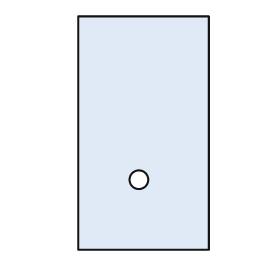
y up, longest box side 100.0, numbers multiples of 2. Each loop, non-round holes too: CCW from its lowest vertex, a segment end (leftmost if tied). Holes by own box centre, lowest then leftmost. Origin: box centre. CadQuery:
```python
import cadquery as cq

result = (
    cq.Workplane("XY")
    .moveTo(-28.0, -50.0)
    .lineTo(28.0, -50.0)
    .lineTo(28.0, 50.0)
    .lineTo(-28.0, 50.0)
    .close()
    .moveTo(-2.0, -20.0)
    .circle(4.0)
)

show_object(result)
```